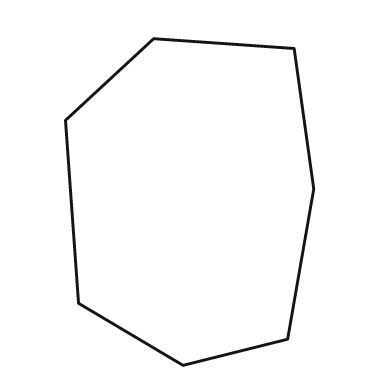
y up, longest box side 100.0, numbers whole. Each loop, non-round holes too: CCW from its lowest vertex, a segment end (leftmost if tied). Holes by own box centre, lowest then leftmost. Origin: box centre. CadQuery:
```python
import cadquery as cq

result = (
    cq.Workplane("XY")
    .moveTo(-2.0, -50.0)
    .lineTo(30.0, -42.0)
    .lineTo(38.0, 4.0)
    .lineTo(32.0, 47.0)
    .lineTo(-11.0, 50.0)
    .lineTo(-38.0, 25.0)
    .lineTo(-34.0, -31.0)
    .close()
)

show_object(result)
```